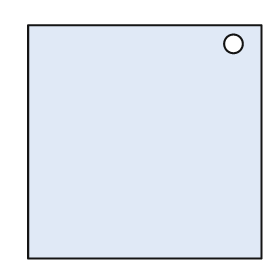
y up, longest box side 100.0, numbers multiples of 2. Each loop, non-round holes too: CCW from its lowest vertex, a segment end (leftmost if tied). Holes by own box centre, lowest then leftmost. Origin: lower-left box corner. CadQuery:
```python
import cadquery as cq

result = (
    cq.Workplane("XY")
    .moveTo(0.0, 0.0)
    .lineTo(100.0, 0.0)
    .lineTo(100.0, 100.0)
    .lineTo(0.0, 100.0)
    .close()
    .moveTo(88.0, 92.0)
    .circle(4.0)
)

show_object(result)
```